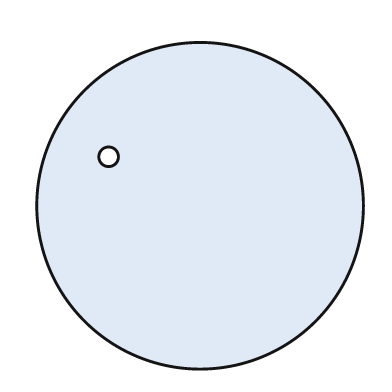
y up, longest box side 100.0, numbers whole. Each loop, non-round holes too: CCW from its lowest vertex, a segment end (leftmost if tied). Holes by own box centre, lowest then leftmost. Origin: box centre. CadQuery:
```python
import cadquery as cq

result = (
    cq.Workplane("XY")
    .moveTo(0.0, 0.0)
    .circle(50.0)
    .moveTo(-28.0, 15.0)
    .circle(3.0)
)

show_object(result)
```